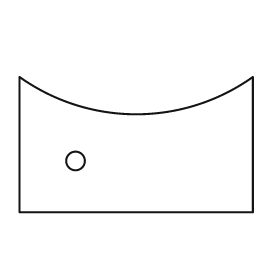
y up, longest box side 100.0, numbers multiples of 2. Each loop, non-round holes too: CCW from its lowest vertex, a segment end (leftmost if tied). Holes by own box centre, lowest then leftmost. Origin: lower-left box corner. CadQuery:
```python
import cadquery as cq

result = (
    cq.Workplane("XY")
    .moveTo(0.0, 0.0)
    .lineTo(100.0, 0.0)
    .lineTo(100.0, 58.0)
    .threePointArc((50.0, 42.0), (0.0, 58.0))
    .close()
    .moveTo(24.0, 22.0)
    .circle(4.0)
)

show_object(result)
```